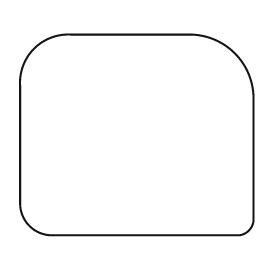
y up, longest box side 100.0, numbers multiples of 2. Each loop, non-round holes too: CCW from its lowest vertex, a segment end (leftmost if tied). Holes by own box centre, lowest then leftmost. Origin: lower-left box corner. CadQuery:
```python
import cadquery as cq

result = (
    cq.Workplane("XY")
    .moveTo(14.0, 0.0)
    .lineTo(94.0, 0.0)
    .threePointArc((98.0, 2.0), (100.0, 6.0))
    .lineTo(100.0, 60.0)
    .threePointArc((92.0, 78.0), (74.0, 86.0))
    .lineTo(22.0, 86.0)
    .threePointArc((6.0, 80.0), (0.0, 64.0))
    .lineTo(0.0, 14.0)
    .threePointArc((4.0, 4.0), (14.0, 0.0))
    .close()
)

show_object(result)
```